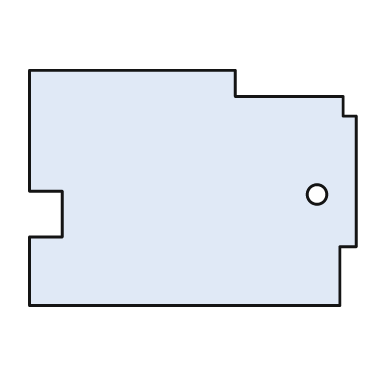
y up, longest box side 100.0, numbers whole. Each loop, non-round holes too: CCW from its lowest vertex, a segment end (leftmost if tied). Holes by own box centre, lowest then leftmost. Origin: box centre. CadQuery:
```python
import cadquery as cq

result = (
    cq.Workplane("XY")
    .moveTo(-50.0, -36.0)
    .lineTo(45.0, -36.0)
    .lineTo(45.0, -18.0)
    .lineTo(50.0, -18.0)
    .lineTo(50.0, 22.0)
    .lineTo(46.0, 22.0)
    .lineTo(46.0, 28.0)
    .lineTo(13.0, 28.0)
    .lineTo(13.0, 36.0)
    .lineTo(-50.0, 36.0)
    .lineTo(-50.0, -1.0)
    .lineTo(-40.0, -1.0)
    .lineTo(-40.0, -15.0)
    .lineTo(-50.0, -15.0)
    .close()
    .moveTo(38.0, -2.0)
    .circle(3.0)
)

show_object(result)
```